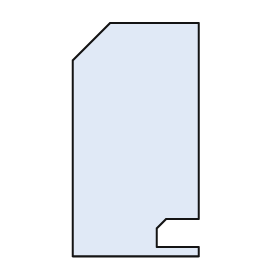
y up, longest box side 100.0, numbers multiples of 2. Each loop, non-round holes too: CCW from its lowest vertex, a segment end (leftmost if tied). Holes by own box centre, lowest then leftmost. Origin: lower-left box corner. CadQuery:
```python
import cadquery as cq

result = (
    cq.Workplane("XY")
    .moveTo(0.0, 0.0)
    .lineTo(54.0, 0.0)
    .lineTo(54.0, 4.0)
    .lineTo(36.0, 4.0)
    .lineTo(36.0, 12.0)
    .lineTo(40.0, 16.0)
    .lineTo(54.0, 16.0)
    .lineTo(54.0, 100.0)
    .lineTo(16.0, 100.0)
    .lineTo(0.0, 84.0)
    .close()
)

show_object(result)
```